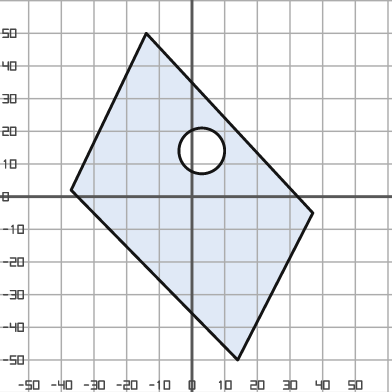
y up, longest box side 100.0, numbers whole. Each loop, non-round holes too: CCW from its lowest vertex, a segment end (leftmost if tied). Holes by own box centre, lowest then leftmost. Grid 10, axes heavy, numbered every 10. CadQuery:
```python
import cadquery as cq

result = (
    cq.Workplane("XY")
    .moveTo(14.0, -50.0)
    .lineTo(37.0, -5.0)
    .lineTo(-14.0, 50.0)
    .lineTo(-37.0, 2.0)
    .close()
    .moveTo(3.0, 14.0)
    .circle(7.0)
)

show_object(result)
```